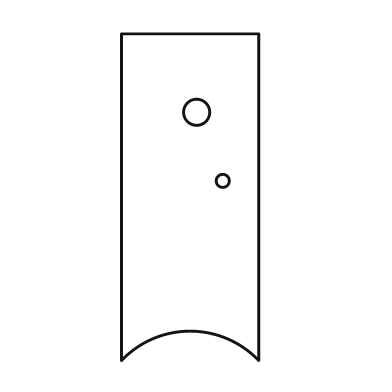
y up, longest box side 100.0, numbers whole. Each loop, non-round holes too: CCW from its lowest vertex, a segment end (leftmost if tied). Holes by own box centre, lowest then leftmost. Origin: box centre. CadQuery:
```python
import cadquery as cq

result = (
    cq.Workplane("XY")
    .moveTo(-21.0, -50.0)
    .threePointArc((0.0, -41.0), (21.0, -50.0))
    .lineTo(21.0, 50.0)
    .lineTo(-21.0, 50.0)
    .close()
    .moveTo(10.0, 5.0)
    .circle(2.0)
    .moveTo(2.0, 26.0)
    .circle(4.0)
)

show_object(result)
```